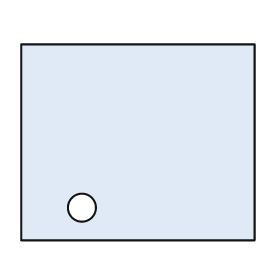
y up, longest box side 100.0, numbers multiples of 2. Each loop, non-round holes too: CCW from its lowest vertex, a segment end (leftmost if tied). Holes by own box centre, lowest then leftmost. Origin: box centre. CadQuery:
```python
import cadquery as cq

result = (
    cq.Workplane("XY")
    .moveTo(-50.0, -42.0)
    .lineTo(50.0, -42.0)
    .lineTo(50.0, 42.0)
    .lineTo(-50.0, 42.0)
    .close()
    .moveTo(-24.0, -28.0)
    .circle(6.0)
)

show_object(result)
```